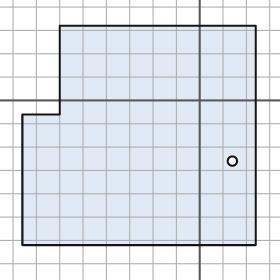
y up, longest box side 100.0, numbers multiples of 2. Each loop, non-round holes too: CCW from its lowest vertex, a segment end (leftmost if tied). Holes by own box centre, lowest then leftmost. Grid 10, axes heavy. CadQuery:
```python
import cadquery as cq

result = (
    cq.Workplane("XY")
    .moveTo(-76.0, -62.0)
    .lineTo(24.0, -62.0)
    .lineTo(24.0, 32.0)
    .lineTo(-60.0, 32.0)
    .lineTo(-60.0, -6.0)
    .lineTo(-76.0, -6.0)
    .close()
    .moveTo(14.0, -26.0)
    .circle(2.0)
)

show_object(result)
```